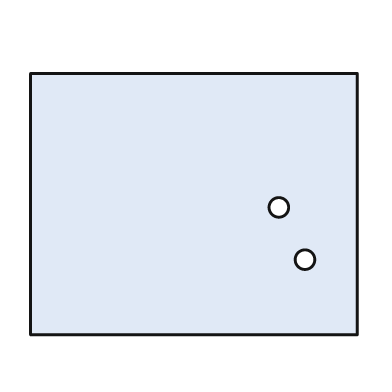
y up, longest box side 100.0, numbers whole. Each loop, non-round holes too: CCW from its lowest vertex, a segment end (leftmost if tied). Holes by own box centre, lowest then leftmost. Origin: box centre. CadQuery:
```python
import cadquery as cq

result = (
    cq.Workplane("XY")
    .moveTo(-50.0, -40.0)
    .lineTo(50.0, -40.0)
    .lineTo(50.0, 40.0)
    .lineTo(-50.0, 40.0)
    .close()
    .moveTo(34.0, -17.0)
    .circle(3.0)
    .moveTo(26.0, -1.0)
    .circle(3.0)
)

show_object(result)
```